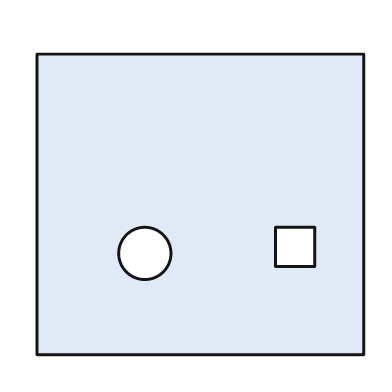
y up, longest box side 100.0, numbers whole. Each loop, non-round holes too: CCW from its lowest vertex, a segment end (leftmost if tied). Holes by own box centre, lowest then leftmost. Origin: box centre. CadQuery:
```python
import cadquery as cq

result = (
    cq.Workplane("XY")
    .moveTo(-50.0, -46.0)
    .lineTo(50.0, -46.0)
    .lineTo(50.0, 46.0)
    .lineTo(-50.0, 46.0)
    .close()
    .moveTo(-17.0, -15.0)
    .circle(8.0)
    .moveTo(23.0, -19.0)
    .lineTo(35.0, -19.0)
    .lineTo(35.0, -7.0)
    .lineTo(23.0, -7.0)
    .close()
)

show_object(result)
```